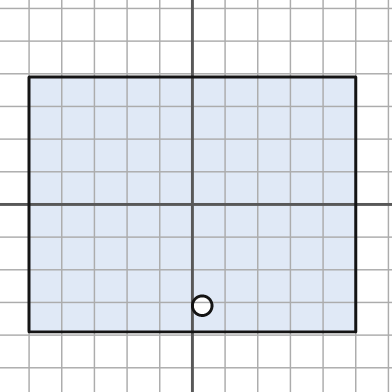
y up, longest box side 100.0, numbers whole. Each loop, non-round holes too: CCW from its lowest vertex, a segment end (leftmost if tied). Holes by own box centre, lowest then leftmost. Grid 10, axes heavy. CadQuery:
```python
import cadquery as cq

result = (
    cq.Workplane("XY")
    .moveTo(-50.0, -39.0)
    .lineTo(50.0, -39.0)
    .lineTo(50.0, 39.0)
    .lineTo(-50.0, 39.0)
    .close()
    .moveTo(3.0, -31.0)
    .circle(3.0)
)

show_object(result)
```